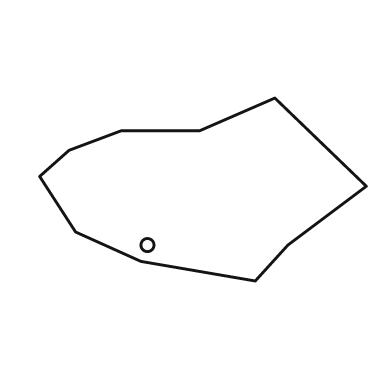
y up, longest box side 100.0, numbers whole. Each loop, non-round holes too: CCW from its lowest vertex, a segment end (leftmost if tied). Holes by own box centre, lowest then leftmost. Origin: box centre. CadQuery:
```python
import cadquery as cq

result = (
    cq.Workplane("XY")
    .moveTo(16.0, -28.0)
    .lineTo(26.0, -17.0)
    .lineTo(50.0, 1.0)
    .lineTo(22.0, 28.0)
    .lineTo(-1.0, 18.0)
    .lineTo(-25.0, 18.0)
    .lineTo(-41.0, 12.0)
    .lineTo(-50.0, 4.0)
    .lineTo(-39.0, -13.0)
    .lineTo(-19.0, -22.0)
    .close()
    .moveTo(-17.0, -17.0)
    .circle(2.0)
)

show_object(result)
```